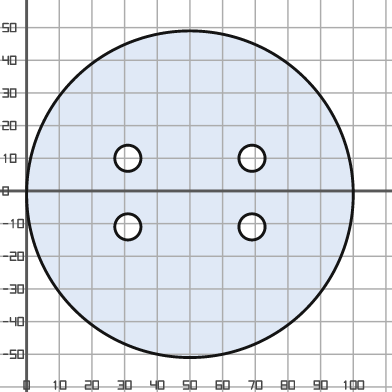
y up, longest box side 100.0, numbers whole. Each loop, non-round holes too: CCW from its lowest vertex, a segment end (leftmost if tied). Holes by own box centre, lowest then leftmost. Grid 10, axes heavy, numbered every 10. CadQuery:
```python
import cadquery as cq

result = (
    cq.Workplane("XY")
    .moveTo(50.0, -1.0)
    .circle(50.0)
    .moveTo(31.0, -11.0)
    .circle(4.0)
    .moveTo(69.0, -11.0)
    .circle(4.0)
    .moveTo(31.0, 10.0)
    .circle(4.0)
    .moveTo(69.0, 10.0)
    .circle(4.0)
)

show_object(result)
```